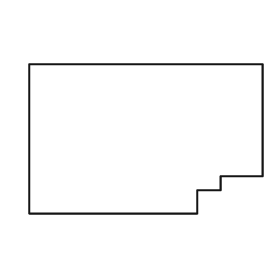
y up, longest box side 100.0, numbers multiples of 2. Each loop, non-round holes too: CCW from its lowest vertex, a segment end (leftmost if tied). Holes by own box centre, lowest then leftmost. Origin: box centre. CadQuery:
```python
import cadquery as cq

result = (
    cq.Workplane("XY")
    .moveTo(-50.0, -32.0)
    .lineTo(22.0, -32.0)
    .lineTo(22.0, -22.0)
    .lineTo(32.0, -22.0)
    .lineTo(32.0, -16.0)
    .lineTo(50.0, -16.0)
    .lineTo(50.0, 32.0)
    .lineTo(-50.0, 32.0)
    .close()
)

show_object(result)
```